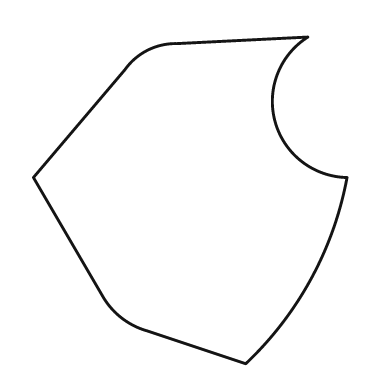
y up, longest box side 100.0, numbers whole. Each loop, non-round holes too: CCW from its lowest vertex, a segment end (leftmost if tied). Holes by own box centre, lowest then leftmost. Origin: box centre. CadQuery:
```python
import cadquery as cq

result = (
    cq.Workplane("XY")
    .moveTo(17.0, -50.0)
    .threePointArc((37.0, -24.0), (48.0, 7.0))
    .threePointArc((26.0, 24.0), (36.0, 50.0))
    .lineTo(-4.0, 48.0)
    .threePointArc((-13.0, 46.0), (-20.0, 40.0))
    .lineTo(-48.0, 7.0)
    .lineTo(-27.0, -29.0)
    .threePointArc((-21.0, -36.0), (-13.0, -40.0))
    .close()
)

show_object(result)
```